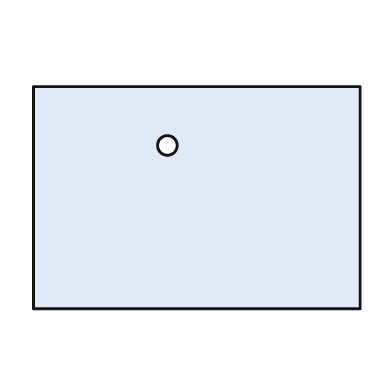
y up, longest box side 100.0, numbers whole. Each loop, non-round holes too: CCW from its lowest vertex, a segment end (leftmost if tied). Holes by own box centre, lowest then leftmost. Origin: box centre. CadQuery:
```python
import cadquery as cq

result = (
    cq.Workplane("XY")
    .moveTo(-50.0, -34.0)
    .lineTo(50.0, -34.0)
    .lineTo(50.0, 34.0)
    .lineTo(-50.0, 34.0)
    .close()
    .moveTo(-9.0, 16.0)
    .circle(3.0)
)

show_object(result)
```